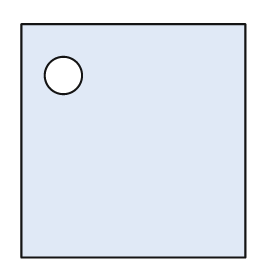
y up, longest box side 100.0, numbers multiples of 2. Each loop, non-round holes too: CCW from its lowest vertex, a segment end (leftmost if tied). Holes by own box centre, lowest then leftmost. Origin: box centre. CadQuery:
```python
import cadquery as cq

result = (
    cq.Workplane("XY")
    .moveTo(-48.0, -50.0)
    .lineTo(48.0, -50.0)
    .lineTo(48.0, 50.0)
    .lineTo(-48.0, 50.0)
    .close()
    .moveTo(-30.0, 28.0)
    .circle(8.0)
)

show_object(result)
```